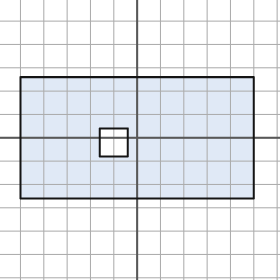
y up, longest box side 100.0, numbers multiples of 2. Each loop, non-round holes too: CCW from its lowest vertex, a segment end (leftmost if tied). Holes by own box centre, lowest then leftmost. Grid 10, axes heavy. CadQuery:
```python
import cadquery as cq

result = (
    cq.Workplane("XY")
    .moveTo(-50.0, -26.0)
    .lineTo(50.0, -26.0)
    .lineTo(50.0, 26.0)
    .lineTo(-50.0, 26.0)
    .close()
    .moveTo(-16.0, -8.0)
    .lineTo(-4.0, -8.0)
    .lineTo(-4.0, 4.0)
    .lineTo(-16.0, 4.0)
    .close()
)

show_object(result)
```